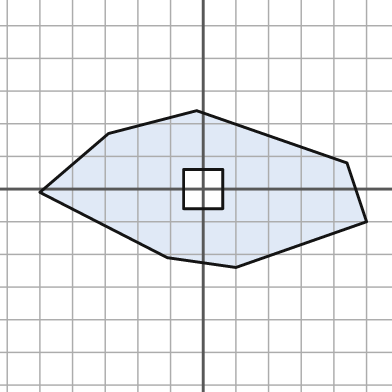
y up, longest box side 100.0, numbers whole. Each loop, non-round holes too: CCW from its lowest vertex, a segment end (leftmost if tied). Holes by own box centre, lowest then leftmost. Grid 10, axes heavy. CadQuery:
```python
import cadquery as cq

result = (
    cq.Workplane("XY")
    .moveTo(10.0, -24.0)
    .lineTo(50.0, -10.0)
    .lineTo(44.0, 8.0)
    .lineTo(-2.0, 24.0)
    .lineTo(-29.0, 17.0)
    .lineTo(-50.0, -1.0)
    .lineTo(-11.0, -21.0)
    .close()
    .moveTo(-6.0, -6.0)
    .lineTo(6.0, -6.0)
    .lineTo(6.0, 6.0)
    .lineTo(-6.0, 6.0)
    .close()
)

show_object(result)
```